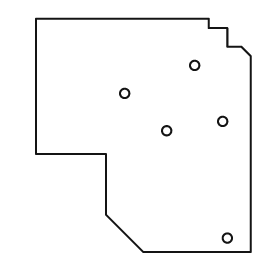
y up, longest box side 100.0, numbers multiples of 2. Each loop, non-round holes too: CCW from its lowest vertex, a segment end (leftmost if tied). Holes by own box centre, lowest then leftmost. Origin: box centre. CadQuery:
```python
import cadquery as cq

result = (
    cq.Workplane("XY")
    .moveTo(0.0, -50.0)
    .lineTo(46.0, -50.0)
    .lineTo(46.0, 34.0)
    .lineTo(42.0, 38.0)
    .lineTo(36.0, 38.0)
    .lineTo(36.0, 46.0)
    .lineTo(28.0, 46.0)
    .lineTo(28.0, 50.0)
    .lineTo(-46.0, 50.0)
    .lineTo(-46.0, -8.0)
    .lineTo(-16.0, -8.0)
    .lineTo(-16.0, -34.0)
    .close()
    .moveTo(36.0, -44.0)
    .circle(2.0)
    .moveTo(10.0, 2.0)
    .circle(2.0)
    .moveTo(34.0, 6.0)
    .circle(2.0)
    .moveTo(-8.0, 18.0)
    .circle(2.0)
    .moveTo(22.0, 30.0)
    .circle(2.0)
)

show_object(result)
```